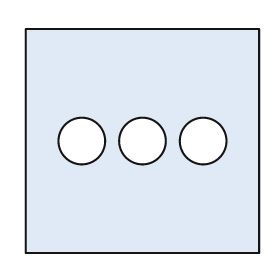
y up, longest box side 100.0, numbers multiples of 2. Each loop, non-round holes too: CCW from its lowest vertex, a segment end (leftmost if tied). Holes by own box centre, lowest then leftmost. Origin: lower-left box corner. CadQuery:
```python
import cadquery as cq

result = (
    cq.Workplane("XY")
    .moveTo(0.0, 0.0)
    .lineTo(100.0, 0.0)
    .lineTo(100.0, 96.0)
    .lineTo(0.0, 96.0)
    .close()
    .moveTo(24.0, 48.0)
    .circle(10.0)
    .moveTo(50.0, 48.0)
    .circle(10.0)
    .moveTo(76.0, 48.0)
    .circle(10.0)
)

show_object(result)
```